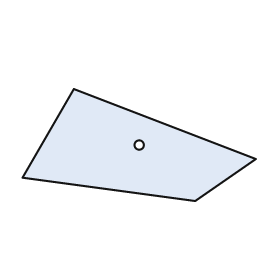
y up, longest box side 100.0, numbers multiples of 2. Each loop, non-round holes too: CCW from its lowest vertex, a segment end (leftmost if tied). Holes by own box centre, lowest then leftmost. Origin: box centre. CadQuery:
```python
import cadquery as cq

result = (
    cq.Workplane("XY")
    .moveTo(24.0, -24.0)
    .lineTo(50.0, -6.0)
    .lineTo(-28.0, 24.0)
    .lineTo(-50.0, -14.0)
    .close()
    .moveTo(0.0, 0.0)
    .circle(2.0)
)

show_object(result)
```